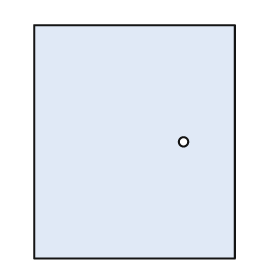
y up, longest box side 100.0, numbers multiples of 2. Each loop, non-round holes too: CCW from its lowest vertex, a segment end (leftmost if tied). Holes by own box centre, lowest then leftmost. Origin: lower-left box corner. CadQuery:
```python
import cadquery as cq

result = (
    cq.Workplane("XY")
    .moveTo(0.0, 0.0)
    .lineTo(86.0, 0.0)
    .lineTo(86.0, 100.0)
    .lineTo(0.0, 100.0)
    .close()
    .moveTo(64.0, 50.0)
    .circle(2.0)
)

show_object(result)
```